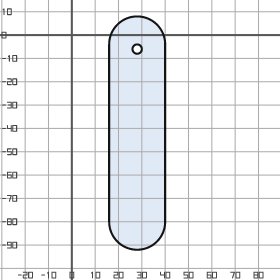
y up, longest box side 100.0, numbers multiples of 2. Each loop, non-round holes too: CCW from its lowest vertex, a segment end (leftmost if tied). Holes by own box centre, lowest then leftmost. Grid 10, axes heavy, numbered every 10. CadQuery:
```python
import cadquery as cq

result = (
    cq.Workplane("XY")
    .moveTo(16.0, -80.0)
    .threePointArc((28.0, -92.0), (40.0, -80.0))
    .lineTo(40.0, -4.0)
    .threePointArc((28.0, 8.0), (16.0, -4.0))
    .close()
    .moveTo(28.0, -6.0)
    .circle(2.0)
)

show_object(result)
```